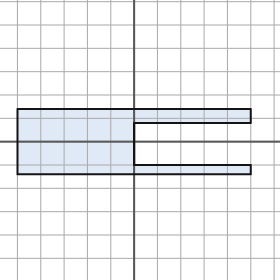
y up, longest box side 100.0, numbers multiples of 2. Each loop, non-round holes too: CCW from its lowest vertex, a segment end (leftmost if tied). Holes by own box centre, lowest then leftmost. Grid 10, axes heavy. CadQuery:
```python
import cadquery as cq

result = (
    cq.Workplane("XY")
    .moveTo(-50.0, -14.0)
    .lineTo(50.0, -14.0)
    .lineTo(50.0, -10.0)
    .lineTo(0.0, -10.0)
    .lineTo(0.0, 8.0)
    .lineTo(50.0, 8.0)
    .lineTo(50.0, 14.0)
    .lineTo(-50.0, 14.0)
    .close()
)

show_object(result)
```